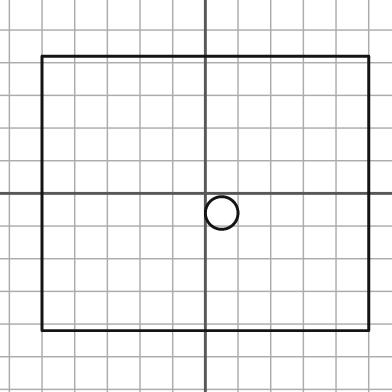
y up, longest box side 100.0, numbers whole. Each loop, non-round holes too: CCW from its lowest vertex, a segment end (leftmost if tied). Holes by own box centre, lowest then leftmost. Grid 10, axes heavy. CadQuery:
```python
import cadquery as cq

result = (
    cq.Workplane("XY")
    .moveTo(-50.0, -42.0)
    .lineTo(50.0, -42.0)
    .lineTo(50.0, 42.0)
    .lineTo(-50.0, 42.0)
    .close()
    .moveTo(5.0, -6.0)
    .circle(5.0)
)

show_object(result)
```